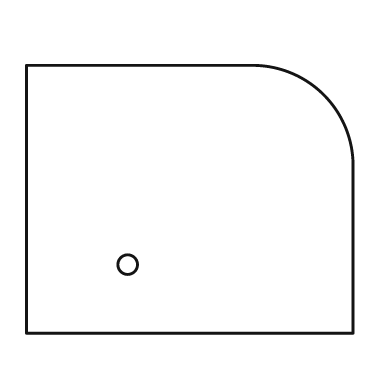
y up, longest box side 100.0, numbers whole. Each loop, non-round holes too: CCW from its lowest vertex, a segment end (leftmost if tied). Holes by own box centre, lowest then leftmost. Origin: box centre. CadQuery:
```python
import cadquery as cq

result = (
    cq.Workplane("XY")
    .moveTo(-50.0, -41.0)
    .lineTo(50.0, -41.0)
    .lineTo(50.0, 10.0)
    .threePointArc((41.0, 32.0), (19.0, 41.0))
    .lineTo(-50.0, 41.0)
    .close()
    .moveTo(-19.0, -20.0)
    .circle(3.0)
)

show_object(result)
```